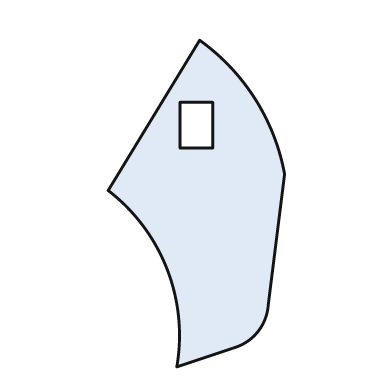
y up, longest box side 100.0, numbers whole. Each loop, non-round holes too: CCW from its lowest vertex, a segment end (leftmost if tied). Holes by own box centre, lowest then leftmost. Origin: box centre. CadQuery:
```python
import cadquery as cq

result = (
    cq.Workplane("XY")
    .moveTo(-6.0, -50.0)
    .lineTo(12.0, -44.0)
    .threePointArc((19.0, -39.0), (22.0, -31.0))
    .lineTo(27.0, 9.0)
    .threePointArc((18.0, 32.0), (1.0, 50.0))
    .lineTo(-27.0, 4.0)
    .threePointArc((-9.0, -20.0), (-6.0, -50.0))
    .close()
    .moveTo(-5.0, 17.0)
    .lineTo(5.0, 17.0)
    .lineTo(5.0, 31.0)
    .lineTo(-5.0, 31.0)
    .close()
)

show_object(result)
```